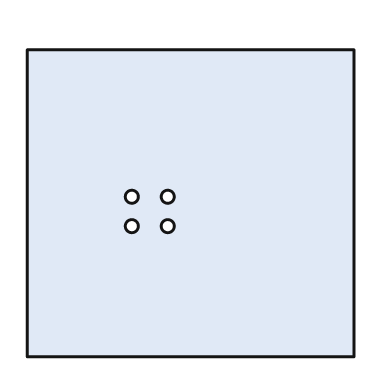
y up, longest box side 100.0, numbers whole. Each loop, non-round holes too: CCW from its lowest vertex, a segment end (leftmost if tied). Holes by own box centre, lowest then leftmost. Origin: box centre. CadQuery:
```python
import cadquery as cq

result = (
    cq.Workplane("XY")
    .moveTo(-50.0, -47.0)
    .lineTo(50.0, -47.0)
    .lineTo(50.0, 47.0)
    .lineTo(-50.0, 47.0)
    .close()
    .moveTo(-18.0, -7.0)
    .circle(2.0)
    .moveTo(-7.0, -7.0)
    .circle(2.0)
    .moveTo(-18.0, 2.0)
    .circle(2.0)
    .moveTo(-7.0, 2.0)
    .circle(2.0)
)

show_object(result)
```